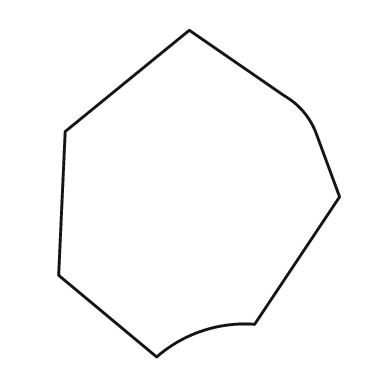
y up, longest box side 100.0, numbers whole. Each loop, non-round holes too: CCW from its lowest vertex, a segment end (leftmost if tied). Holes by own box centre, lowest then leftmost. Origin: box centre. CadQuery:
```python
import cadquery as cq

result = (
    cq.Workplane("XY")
    .moveTo(-13.0, -50.0)
    .threePointArc((1.0, -42.0), (17.0, -40.0))
    .lineTo(43.0, -1.0)
    .lineTo(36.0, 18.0)
    .threePointArc((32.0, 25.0), (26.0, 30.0))
    .lineTo(-3.0, 50.0)
    .lineTo(-41.0, 19.0)
    .lineTo(-43.0, -25.0)
    .close()
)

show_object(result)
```